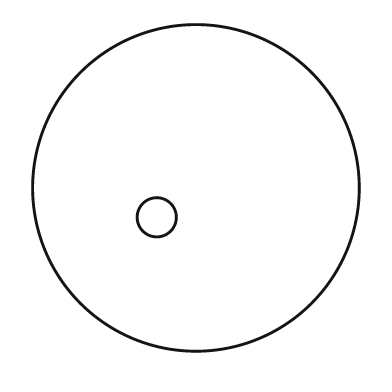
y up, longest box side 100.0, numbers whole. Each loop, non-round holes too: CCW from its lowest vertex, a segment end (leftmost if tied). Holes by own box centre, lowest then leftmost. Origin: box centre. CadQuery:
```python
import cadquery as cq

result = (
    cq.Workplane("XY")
    .moveTo(0.0, 0.0)
    .circle(50.0)
    .moveTo(-12.0, -9.0)
    .circle(6.0)
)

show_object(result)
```